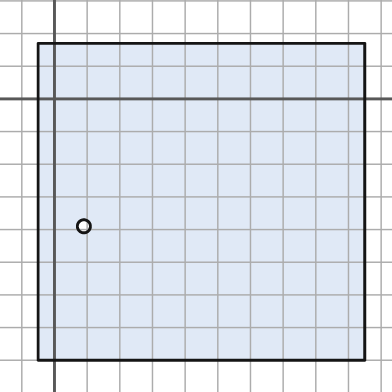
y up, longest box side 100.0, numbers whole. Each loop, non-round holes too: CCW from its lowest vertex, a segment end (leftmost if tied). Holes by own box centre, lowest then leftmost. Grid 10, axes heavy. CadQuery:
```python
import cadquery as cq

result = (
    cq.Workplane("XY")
    .moveTo(-5.0, -80.0)
    .lineTo(95.0, -80.0)
    .lineTo(95.0, 17.0)
    .lineTo(-5.0, 17.0)
    .close()
    .moveTo(9.0, -39.0)
    .circle(2.0)
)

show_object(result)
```